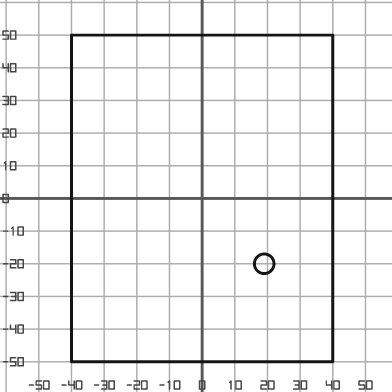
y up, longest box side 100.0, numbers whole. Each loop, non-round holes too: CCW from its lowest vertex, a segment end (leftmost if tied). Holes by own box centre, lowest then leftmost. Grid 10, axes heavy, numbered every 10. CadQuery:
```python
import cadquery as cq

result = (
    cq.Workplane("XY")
    .moveTo(-40.0, -50.0)
    .lineTo(40.0, -50.0)
    .lineTo(40.0, 50.0)
    .lineTo(-40.0, 50.0)
    .close()
    .moveTo(19.0, -20.0)
    .circle(3.0)
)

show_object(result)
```